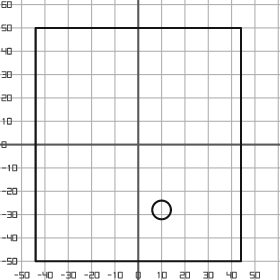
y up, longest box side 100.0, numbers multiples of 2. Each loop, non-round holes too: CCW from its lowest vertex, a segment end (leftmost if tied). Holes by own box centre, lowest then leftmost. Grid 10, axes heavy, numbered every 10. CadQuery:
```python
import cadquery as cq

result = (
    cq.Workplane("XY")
    .moveTo(-44.0, -50.0)
    .lineTo(44.0, -50.0)
    .lineTo(44.0, 50.0)
    .lineTo(-44.0, 50.0)
    .close()
    .moveTo(10.0, -28.0)
    .circle(4.0)
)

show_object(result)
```